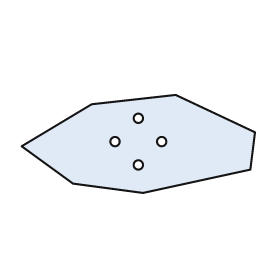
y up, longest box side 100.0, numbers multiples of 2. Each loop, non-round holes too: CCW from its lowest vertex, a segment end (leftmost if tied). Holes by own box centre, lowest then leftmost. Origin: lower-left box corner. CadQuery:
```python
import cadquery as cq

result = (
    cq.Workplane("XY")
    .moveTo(52.0, 0.0)
    .lineTo(98.0, 10.0)
    .lineTo(100.0, 26.0)
    .lineTo(66.0, 42.0)
    .lineTo(30.0, 38.0)
    .lineTo(0.0, 20.0)
    .lineTo(22.0, 4.0)
    .close()
    .moveTo(50.0, 12.0)
    .circle(2.0)
    .moveTo(40.0, 22.0)
    .circle(2.0)
    .moveTo(60.0, 22.0)
    .circle(2.0)
    .moveTo(50.0, 32.0)
    .circle(2.0)
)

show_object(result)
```